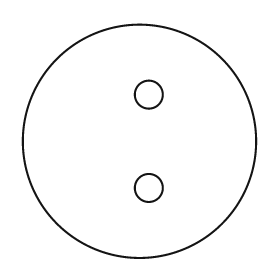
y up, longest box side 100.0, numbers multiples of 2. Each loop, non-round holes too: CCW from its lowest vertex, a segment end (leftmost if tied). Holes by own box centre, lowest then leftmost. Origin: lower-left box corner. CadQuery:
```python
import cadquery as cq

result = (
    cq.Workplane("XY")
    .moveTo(50.0, 50.0)
    .circle(50.0)
    .moveTo(54.0, 30.0)
    .circle(6.0)
    .moveTo(54.0, 70.0)
    .circle(6.0)
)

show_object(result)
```